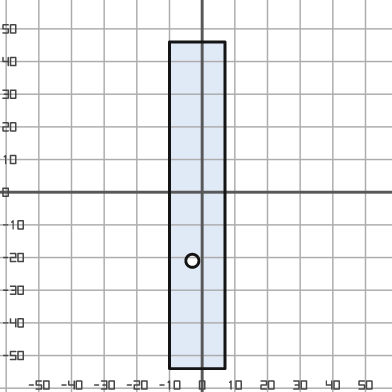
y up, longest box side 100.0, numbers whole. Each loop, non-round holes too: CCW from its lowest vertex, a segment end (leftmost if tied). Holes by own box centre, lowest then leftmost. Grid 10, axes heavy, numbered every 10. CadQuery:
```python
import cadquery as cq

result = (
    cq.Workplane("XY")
    .moveTo(-10.0, -54.0)
    .lineTo(7.0, -54.0)
    .lineTo(7.0, 46.0)
    .lineTo(-10.0, 46.0)
    .close()
    .moveTo(-3.0, -21.0)
    .circle(2.0)
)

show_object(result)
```